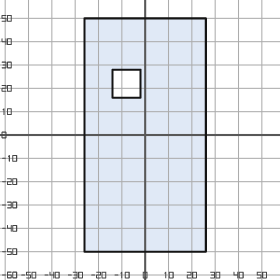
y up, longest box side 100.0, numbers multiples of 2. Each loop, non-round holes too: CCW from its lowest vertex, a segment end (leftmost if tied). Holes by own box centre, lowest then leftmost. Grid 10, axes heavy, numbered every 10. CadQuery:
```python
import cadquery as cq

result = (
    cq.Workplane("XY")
    .moveTo(-26.0, -50.0)
    .lineTo(26.0, -50.0)
    .lineTo(26.0, 50.0)
    .lineTo(-26.0, 50.0)
    .close()
    .moveTo(-14.0, 16.0)
    .lineTo(-2.0, 16.0)
    .lineTo(-2.0, 28.0)
    .lineTo(-14.0, 28.0)
    .close()
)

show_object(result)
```